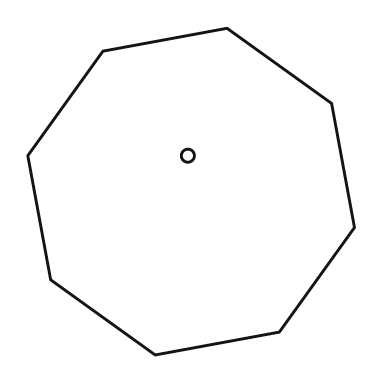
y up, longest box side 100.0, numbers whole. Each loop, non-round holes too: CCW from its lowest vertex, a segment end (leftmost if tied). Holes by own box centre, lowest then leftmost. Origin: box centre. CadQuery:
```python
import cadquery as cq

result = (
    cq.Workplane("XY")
    .moveTo(-11.0, -50.0)
    .lineTo(27.0, -43.0)
    .lineTo(50.0, -11.0)
    .lineTo(43.0, 27.0)
    .lineTo(11.0, 50.0)
    .lineTo(-27.0, 43.0)
    .lineTo(-50.0, 11.0)
    .lineTo(-43.0, -27.0)
    .close()
    .moveTo(-1.0, 11.0)
    .circle(2.0)
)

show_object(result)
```